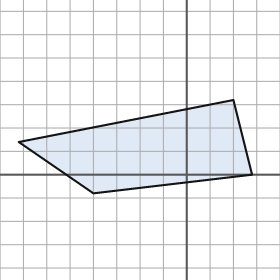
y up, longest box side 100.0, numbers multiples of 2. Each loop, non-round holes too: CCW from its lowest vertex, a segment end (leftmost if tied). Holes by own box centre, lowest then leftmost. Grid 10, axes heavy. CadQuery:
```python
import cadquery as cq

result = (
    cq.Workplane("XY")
    .moveTo(-40.0, -8.0)
    .lineTo(28.0, 0.0)
    .lineTo(20.0, 32.0)
    .lineTo(-72.0, 14.0)
    .close()
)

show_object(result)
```